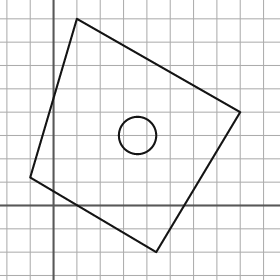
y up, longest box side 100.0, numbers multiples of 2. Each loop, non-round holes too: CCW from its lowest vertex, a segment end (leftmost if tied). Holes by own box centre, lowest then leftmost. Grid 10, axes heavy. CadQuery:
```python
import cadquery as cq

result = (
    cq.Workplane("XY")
    .moveTo(44.0, -20.0)
    .lineTo(80.0, 40.0)
    .lineTo(10.0, 80.0)
    .lineTo(-10.0, 12.0)
    .close()
    .moveTo(36.0, 30.0)
    .circle(8.0)
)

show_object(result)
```